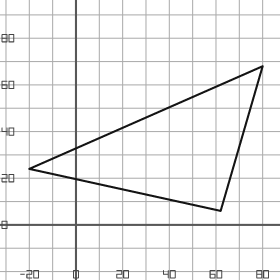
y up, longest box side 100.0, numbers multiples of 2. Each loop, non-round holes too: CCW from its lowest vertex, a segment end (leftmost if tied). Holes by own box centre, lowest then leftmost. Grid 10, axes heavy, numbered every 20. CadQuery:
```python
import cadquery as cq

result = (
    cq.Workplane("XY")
    .moveTo(62.0, 6.0)
    .lineTo(80.0, 68.0)
    .lineTo(-20.0, 24.0)
    .close()
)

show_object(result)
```